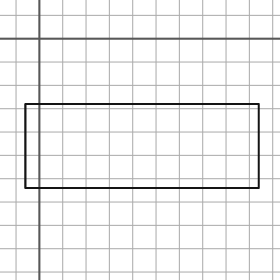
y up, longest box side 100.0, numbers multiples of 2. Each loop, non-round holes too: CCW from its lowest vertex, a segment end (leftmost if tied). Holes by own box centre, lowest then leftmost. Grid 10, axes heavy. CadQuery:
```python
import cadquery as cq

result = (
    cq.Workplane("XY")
    .moveTo(-6.0, -64.0)
    .lineTo(94.0, -64.0)
    .lineTo(94.0, -28.0)
    .lineTo(-6.0, -28.0)
    .close()
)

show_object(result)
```